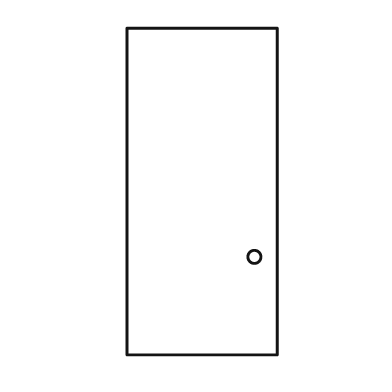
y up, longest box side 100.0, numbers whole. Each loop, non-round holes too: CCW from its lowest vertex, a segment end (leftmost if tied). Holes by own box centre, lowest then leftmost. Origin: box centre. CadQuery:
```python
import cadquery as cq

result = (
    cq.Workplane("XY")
    .moveTo(-23.0, -50.0)
    .lineTo(23.0, -50.0)
    .lineTo(23.0, 50.0)
    .lineTo(-23.0, 50.0)
    .close()
    .moveTo(16.0, -20.0)
    .circle(2.0)
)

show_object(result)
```